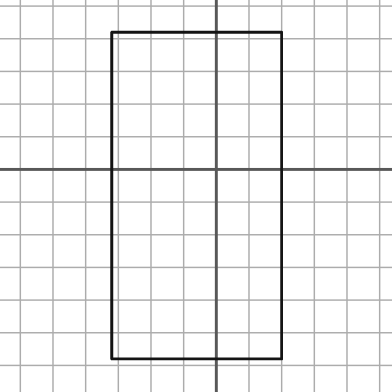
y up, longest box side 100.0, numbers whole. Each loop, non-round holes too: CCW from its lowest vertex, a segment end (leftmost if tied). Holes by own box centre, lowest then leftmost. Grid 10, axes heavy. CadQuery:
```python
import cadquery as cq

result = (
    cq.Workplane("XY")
    .moveTo(-32.0, -58.0)
    .lineTo(20.0, -58.0)
    .lineTo(20.0, 42.0)
    .lineTo(-32.0, 42.0)
    .close()
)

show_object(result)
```